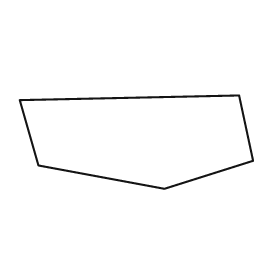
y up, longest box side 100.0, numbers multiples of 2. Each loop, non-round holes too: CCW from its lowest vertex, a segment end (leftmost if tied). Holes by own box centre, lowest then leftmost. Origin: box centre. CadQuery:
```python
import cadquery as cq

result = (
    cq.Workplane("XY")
    .moveTo(12.0, -20.0)
    .lineTo(50.0, -8.0)
    .lineTo(44.0, 20.0)
    .lineTo(-50.0, 18.0)
    .lineTo(-42.0, -10.0)
    .close()
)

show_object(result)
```